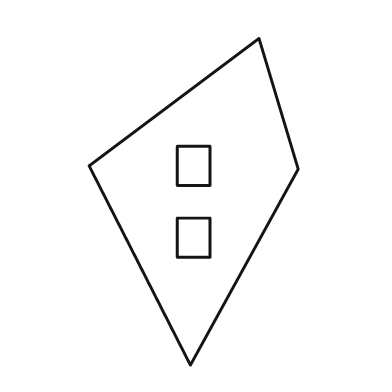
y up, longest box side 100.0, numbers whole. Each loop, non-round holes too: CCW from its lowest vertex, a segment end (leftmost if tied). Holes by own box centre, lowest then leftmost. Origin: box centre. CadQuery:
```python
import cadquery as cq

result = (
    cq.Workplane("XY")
    .moveTo(-1.0, -50.0)
    .lineTo(32.0, 10.0)
    .lineTo(20.0, 50.0)
    .lineTo(-32.0, 11.0)
    .close()
    .moveTo(-5.0, -17.0)
    .lineTo(5.0, -17.0)
    .lineTo(5.0, -5.0)
    .lineTo(-5.0, -5.0)
    .close()
    .moveTo(-5.0, 5.0)
    .lineTo(5.0, 5.0)
    .lineTo(5.0, 17.0)
    .lineTo(-5.0, 17.0)
    .close()
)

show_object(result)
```